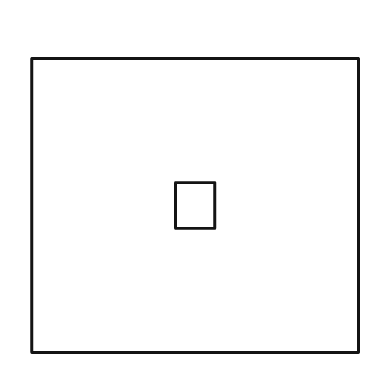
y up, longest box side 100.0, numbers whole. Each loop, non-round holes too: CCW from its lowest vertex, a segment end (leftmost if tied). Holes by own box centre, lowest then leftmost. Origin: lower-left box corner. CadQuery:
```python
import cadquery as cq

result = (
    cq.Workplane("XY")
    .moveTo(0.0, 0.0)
    .lineTo(100.0, 0.0)
    .lineTo(100.0, 90.0)
    .lineTo(0.0, 90.0)
    .close()
    .moveTo(44.0, 38.0)
    .lineTo(56.0, 38.0)
    .lineTo(56.0, 52.0)
    .lineTo(44.0, 52.0)
    .close()
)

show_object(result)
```